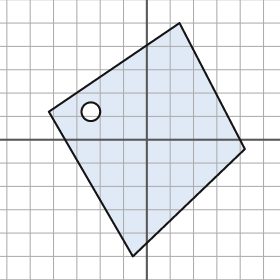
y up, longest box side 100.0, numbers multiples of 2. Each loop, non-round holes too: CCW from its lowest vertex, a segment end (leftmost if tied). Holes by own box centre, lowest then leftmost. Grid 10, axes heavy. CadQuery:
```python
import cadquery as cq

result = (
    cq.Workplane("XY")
    .moveTo(-6.0, -50.0)
    .lineTo(42.0, -4.0)
    .lineTo(14.0, 50.0)
    .lineTo(-42.0, 12.0)
    .close()
    .moveTo(-24.0, 12.0)
    .circle(4.0)
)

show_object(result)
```